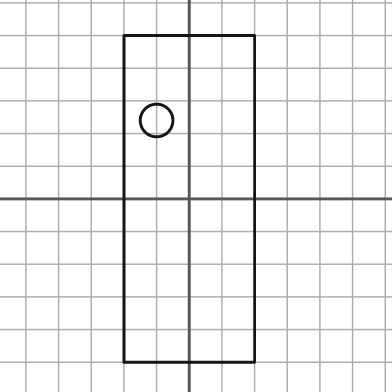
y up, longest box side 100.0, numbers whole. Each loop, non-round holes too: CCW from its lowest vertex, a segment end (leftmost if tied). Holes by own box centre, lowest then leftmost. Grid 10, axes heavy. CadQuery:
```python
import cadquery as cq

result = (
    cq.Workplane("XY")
    .moveTo(-20.0, -50.0)
    .lineTo(20.0, -50.0)
    .lineTo(20.0, 50.0)
    .lineTo(-20.0, 50.0)
    .close()
    .moveTo(-10.0, 24.0)
    .circle(5.0)
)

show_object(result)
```